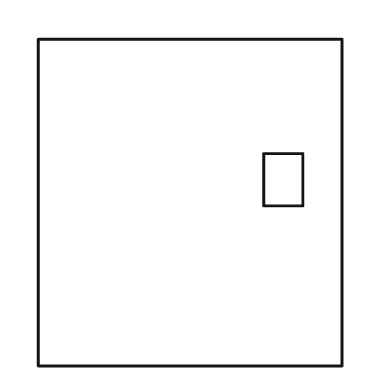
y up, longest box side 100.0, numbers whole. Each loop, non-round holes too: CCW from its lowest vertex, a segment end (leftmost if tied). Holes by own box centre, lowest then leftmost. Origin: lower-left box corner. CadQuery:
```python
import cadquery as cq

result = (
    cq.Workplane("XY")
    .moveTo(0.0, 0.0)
    .lineTo(93.0, 0.0)
    .lineTo(93.0, 100.0)
    .lineTo(0.0, 100.0)
    .close()
    .moveTo(69.0, 49.0)
    .lineTo(81.0, 49.0)
    .lineTo(81.0, 65.0)
    .lineTo(69.0, 65.0)
    .close()
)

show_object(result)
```